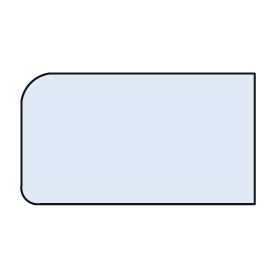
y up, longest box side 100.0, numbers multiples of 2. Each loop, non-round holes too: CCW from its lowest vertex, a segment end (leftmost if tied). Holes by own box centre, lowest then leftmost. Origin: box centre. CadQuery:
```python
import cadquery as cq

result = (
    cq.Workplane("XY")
    .moveTo(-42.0, -28.0)
    .lineTo(50.0, -28.0)
    .lineTo(50.0, 28.0)
    .lineTo(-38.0, 28.0)
    .threePointArc((-46.0, 24.0), (-50.0, 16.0))
    .lineTo(-50.0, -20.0)
    .threePointArc((-48.0, -26.0), (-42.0, -28.0))
    .close()
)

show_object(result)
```